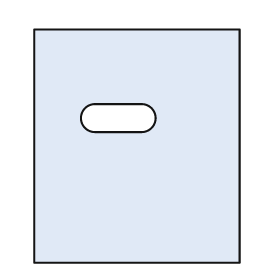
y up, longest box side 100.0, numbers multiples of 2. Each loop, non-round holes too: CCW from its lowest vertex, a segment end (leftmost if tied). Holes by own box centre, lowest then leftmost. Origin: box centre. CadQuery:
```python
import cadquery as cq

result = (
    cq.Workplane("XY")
    .moveTo(-44.0, -50.0)
    .lineTo(44.0, -50.0)
    .lineTo(44.0, 50.0)
    .lineTo(-44.0, 50.0)
    .close()
    .moveTo(-18.0, 6.0)
    .lineTo(2.0, 6.0)
    .threePointArc((8.0, 12.0), (2.0, 18.0))
    .lineTo(-18.0, 18.0)
    .threePointArc((-24.0, 12.0), (-18.0, 6.0))
    .close()
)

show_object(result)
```